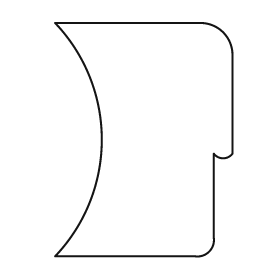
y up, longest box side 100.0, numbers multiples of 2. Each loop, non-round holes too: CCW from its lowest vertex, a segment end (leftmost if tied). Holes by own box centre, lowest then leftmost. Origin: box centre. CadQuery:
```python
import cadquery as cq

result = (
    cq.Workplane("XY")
    .moveTo(-38.0, -50.0)
    .lineTo(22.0, -50.0)
    .threePointArc((28.0, -48.0), (30.0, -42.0))
    .lineTo(30.0, -6.0)
    .threePointArc((34.0, -8.0), (38.0, -6.0))
    .lineTo(38.0, 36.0)
    .threePointArc((34.0, 46.0), (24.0, 50.0))
    .lineTo(-38.0, 50.0)
    .threePointArc((-18.0, 0.0), (-38.0, -50.0))
    .close()
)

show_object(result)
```